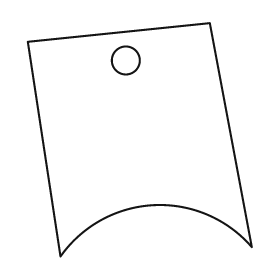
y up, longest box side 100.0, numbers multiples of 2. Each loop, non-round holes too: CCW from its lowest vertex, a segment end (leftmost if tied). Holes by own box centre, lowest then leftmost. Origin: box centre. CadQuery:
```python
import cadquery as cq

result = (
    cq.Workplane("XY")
    .moveTo(-34.0, -50.0)
    .threePointArc((6.0, -28.0), (48.0, -46.0))
    .lineTo(30.0, 50.0)
    .lineTo(-48.0, 42.0)
    .close()
    .moveTo(-6.0, 34.0)
    .circle(6.0)
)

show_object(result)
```